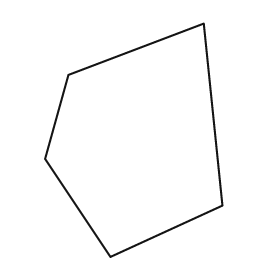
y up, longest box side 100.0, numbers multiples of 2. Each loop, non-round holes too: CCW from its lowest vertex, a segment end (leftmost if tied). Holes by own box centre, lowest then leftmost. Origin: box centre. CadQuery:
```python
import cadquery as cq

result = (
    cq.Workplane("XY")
    .moveTo(-10.0, -50.0)
    .lineTo(38.0, -28.0)
    .lineTo(30.0, 50.0)
    .lineTo(-28.0, 28.0)
    .lineTo(-38.0, -8.0)
    .close()
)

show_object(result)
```